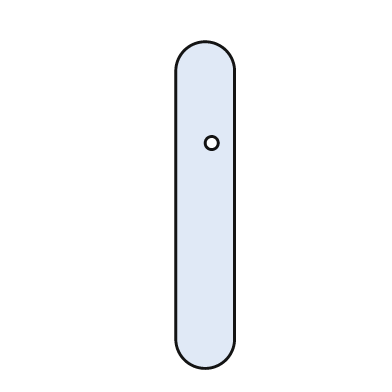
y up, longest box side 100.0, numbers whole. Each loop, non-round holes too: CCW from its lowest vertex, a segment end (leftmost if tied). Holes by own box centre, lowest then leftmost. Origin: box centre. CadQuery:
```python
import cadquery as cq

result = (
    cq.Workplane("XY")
    .moveTo(-9.0, -41.0)
    .threePointArc((0.0, -50.0), (9.0, -41.0))
    .lineTo(9.0, 41.0)
    .threePointArc((0.0, 50.0), (-9.0, 41.0))
    .close()
    .moveTo(2.0, 19.0)
    .circle(2.0)
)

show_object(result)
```